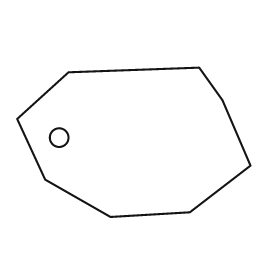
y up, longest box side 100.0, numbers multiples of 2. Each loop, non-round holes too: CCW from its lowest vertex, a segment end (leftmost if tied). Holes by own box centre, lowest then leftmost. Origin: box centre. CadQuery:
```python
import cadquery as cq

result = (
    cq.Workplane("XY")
    .moveTo(-10.0, -32.0)
    .lineTo(24.0, -30.0)
    .lineTo(50.0, -10.0)
    .lineTo(38.0, 18.0)
    .lineTo(28.0, 32.0)
    .lineTo(-28.0, 30.0)
    .lineTo(-50.0, 10.0)
    .lineTo(-38.0, -16.0)
    .close()
    .moveTo(-32.0, 2.0)
    .circle(4.0)
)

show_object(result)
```